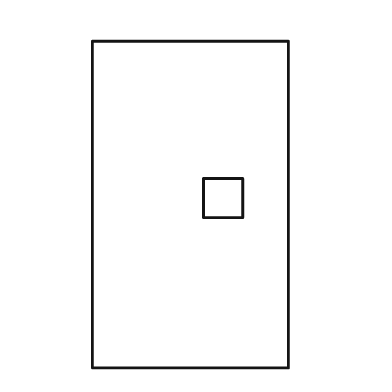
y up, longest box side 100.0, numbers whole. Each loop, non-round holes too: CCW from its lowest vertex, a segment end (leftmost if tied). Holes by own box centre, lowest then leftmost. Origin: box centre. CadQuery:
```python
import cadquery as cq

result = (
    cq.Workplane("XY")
    .moveTo(-30.0, -50.0)
    .lineTo(30.0, -50.0)
    .lineTo(30.0, 50.0)
    .lineTo(-30.0, 50.0)
    .close()
    .moveTo(4.0, -4.0)
    .lineTo(16.0, -4.0)
    .lineTo(16.0, 8.0)
    .lineTo(4.0, 8.0)
    .close()
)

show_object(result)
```